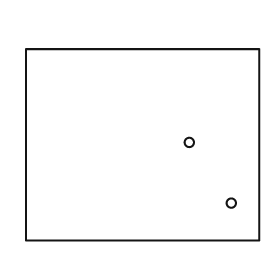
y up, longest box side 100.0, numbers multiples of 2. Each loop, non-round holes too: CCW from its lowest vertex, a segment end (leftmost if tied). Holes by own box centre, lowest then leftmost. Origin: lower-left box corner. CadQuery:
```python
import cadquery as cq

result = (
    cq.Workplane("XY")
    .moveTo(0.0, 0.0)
    .lineTo(100.0, 0.0)
    .lineTo(100.0, 82.0)
    .lineTo(0.0, 82.0)
    .close()
    .moveTo(88.0, 16.0)
    .circle(2.0)
    .moveTo(70.0, 42.0)
    .circle(2.0)
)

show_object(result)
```